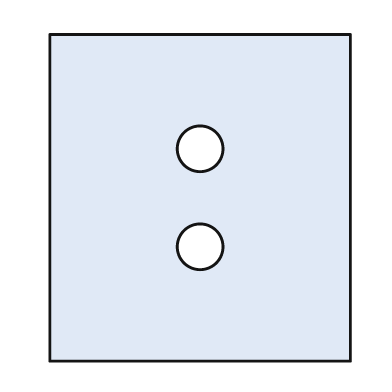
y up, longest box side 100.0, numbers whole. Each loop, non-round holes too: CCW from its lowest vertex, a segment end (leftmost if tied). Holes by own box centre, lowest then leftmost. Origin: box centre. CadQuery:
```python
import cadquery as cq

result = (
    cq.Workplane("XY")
    .moveTo(-46.0, -50.0)
    .lineTo(46.0, -50.0)
    .lineTo(46.0, 50.0)
    .lineTo(-46.0, 50.0)
    .close()
    .moveTo(0.0, -15.0)
    .circle(7.0)
    .moveTo(0.0, 15.0)
    .circle(7.0)
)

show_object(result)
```